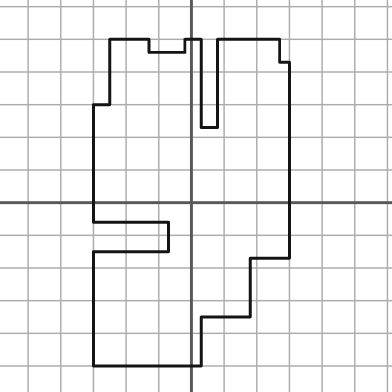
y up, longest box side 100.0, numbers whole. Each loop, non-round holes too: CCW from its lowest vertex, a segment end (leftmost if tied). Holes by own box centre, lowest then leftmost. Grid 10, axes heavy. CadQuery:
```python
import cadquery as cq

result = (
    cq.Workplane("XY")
    .moveTo(-30.0, -50.0)
    .lineTo(3.0, -50.0)
    .lineTo(3.0, -35.0)
    .lineTo(18.0, -35.0)
    .lineTo(18.0, -17.0)
    .lineTo(30.0, -17.0)
    .lineTo(30.0, 43.0)
    .lineTo(27.0, 43.0)
    .lineTo(27.0, 50.0)
    .lineTo(8.0, 50.0)
    .lineTo(8.0, 23.0)
    .lineTo(3.0, 23.0)
    .lineTo(3.0, 50.0)
    .lineTo(-2.0, 50.0)
    .lineTo(-2.0, 46.0)
    .lineTo(-13.0, 46.0)
    .lineTo(-13.0, 50.0)
    .lineTo(-25.0, 50.0)
    .lineTo(-25.0, 30.0)
    .lineTo(-30.0, 30.0)
    .lineTo(-30.0, -6.0)
    .lineTo(-7.0, -6.0)
    .lineTo(-7.0, -15.0)
    .lineTo(-30.0, -15.0)
    .close()
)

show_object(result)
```